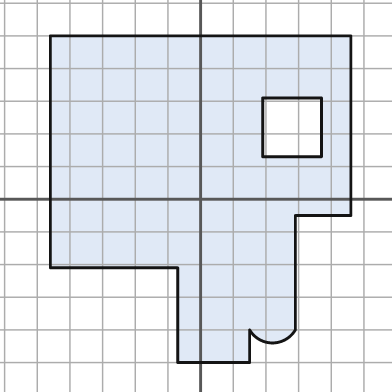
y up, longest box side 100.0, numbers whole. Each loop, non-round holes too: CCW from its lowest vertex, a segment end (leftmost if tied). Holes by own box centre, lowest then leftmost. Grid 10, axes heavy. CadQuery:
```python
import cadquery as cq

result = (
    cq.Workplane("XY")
    .moveTo(-7.0, -50.0)
    .lineTo(15.0, -50.0)
    .lineTo(15.0, -40.0)
    .threePointArc((22.0, -44.0), (29.0, -40.0))
    .lineTo(29.0, -5.0)
    .lineTo(46.0, -5.0)
    .lineTo(46.0, 50.0)
    .lineTo(-46.0, 50.0)
    .lineTo(-46.0, -21.0)
    .lineTo(-7.0, -21.0)
    .close()
    .moveTo(19.0, 13.0)
    .lineTo(37.0, 13.0)
    .lineTo(37.0, 31.0)
    .lineTo(19.0, 31.0)
    .close()
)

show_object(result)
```